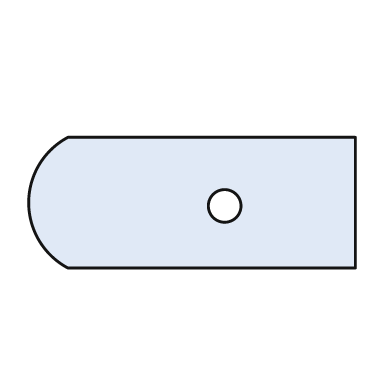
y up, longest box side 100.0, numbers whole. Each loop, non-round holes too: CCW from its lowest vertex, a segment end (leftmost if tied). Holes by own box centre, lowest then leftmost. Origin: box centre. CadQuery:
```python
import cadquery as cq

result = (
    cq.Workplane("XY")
    .moveTo(-38.0, -20.0)
    .lineTo(50.0, -20.0)
    .lineTo(50.0, 20.0)
    .lineTo(-38.0, 20.0)
    .threePointArc((-50.0, 0.0), (-38.0, -20.0))
    .close()
    .moveTo(10.0, -1.0)
    .circle(5.0)
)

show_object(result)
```